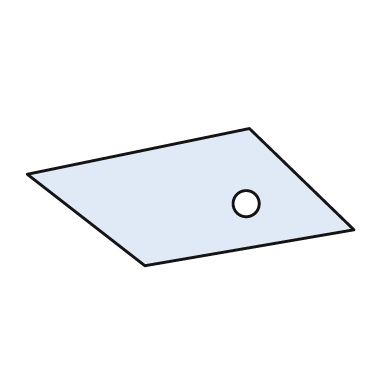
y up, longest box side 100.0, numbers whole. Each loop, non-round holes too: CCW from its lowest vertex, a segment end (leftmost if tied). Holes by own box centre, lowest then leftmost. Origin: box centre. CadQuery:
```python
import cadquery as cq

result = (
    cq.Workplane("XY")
    .moveTo(-14.0, -21.0)
    .lineTo(50.0, -10.0)
    .lineTo(18.0, 21.0)
    .lineTo(-50.0, 7.0)
    .close()
    .moveTo(17.0, -2.0)
    .circle(4.0)
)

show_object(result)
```